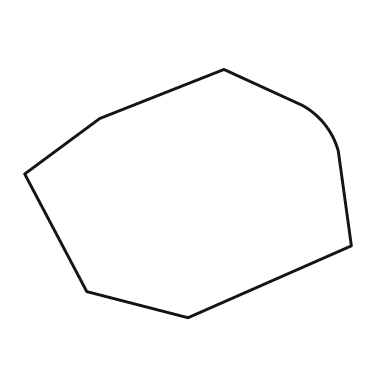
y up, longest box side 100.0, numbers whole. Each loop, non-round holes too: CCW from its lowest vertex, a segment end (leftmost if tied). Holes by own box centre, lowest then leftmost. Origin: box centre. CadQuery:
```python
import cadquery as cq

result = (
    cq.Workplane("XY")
    .moveTo(0.0, -38.0)
    .lineTo(50.0, -16.0)
    .lineTo(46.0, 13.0)
    .threePointArc((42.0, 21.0), (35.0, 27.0))
    .lineTo(11.0, 38.0)
    .lineTo(-27.0, 23.0)
    .lineTo(-50.0, 6.0)
    .lineTo(-31.0, -30.0)
    .close()
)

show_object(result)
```